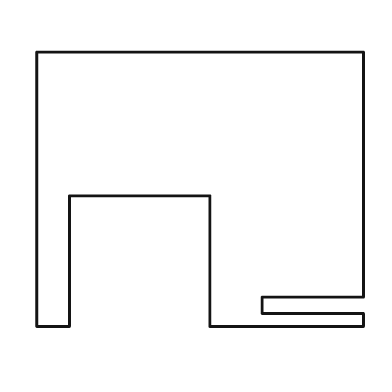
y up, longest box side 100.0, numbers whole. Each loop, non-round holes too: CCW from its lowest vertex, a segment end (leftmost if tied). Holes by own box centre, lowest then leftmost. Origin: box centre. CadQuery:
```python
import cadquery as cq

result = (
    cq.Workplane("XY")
    .moveTo(-50.0, -42.0)
    .lineTo(-40.0, -42.0)
    .lineTo(-40.0, -2.0)
    .lineTo(3.0, -2.0)
    .lineTo(3.0, -42.0)
    .lineTo(50.0, -42.0)
    .lineTo(50.0, -38.0)
    .lineTo(19.0, -38.0)
    .lineTo(19.0, -33.0)
    .lineTo(50.0, -33.0)
    .lineTo(50.0, 42.0)
    .lineTo(-50.0, 42.0)
    .close()
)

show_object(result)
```